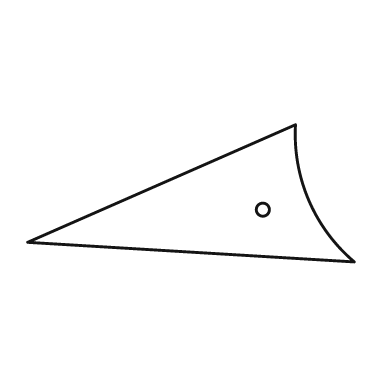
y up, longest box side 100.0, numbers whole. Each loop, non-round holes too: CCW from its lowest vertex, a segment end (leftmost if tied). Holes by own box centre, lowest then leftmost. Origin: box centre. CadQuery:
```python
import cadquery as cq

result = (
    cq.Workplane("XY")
    .moveTo(50.0, -21.0)
    .threePointArc((36.0, -2.0), (32.0, 21.0))
    .lineTo(-50.0, -15.0)
    .close()
    .moveTo(22.0, -5.0)
    .circle(2.0)
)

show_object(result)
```